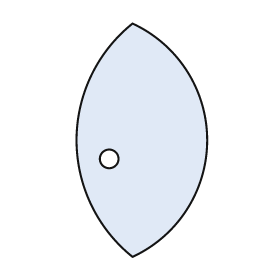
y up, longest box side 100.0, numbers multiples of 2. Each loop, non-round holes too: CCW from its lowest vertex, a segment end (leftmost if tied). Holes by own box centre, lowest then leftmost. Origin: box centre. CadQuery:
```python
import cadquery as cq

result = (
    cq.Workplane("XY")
    .moveTo(-4.0, -50.0)
    .threePointArc((28.0, 0.0), (-4.0, 50.0))
    .threePointArc((-28.0, 0.0), (-4.0, -50.0))
    .close()
    .moveTo(-14.0, -8.0)
    .circle(4.0)
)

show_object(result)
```